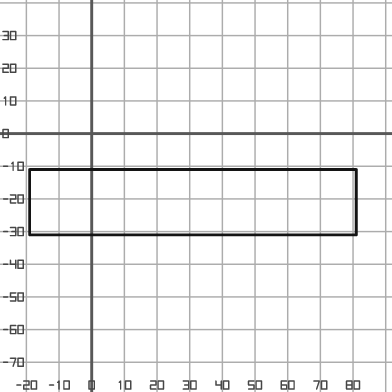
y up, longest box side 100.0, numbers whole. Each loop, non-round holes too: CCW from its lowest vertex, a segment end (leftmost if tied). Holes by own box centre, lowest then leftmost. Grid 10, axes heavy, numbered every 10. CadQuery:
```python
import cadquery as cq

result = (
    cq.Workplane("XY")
    .moveTo(-19.0, -31.0)
    .lineTo(81.0, -31.0)
    .lineTo(81.0, -11.0)
    .lineTo(-19.0, -11.0)
    .close()
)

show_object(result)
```